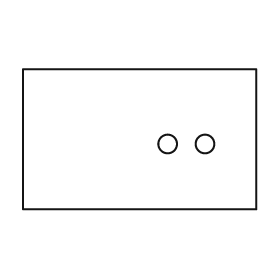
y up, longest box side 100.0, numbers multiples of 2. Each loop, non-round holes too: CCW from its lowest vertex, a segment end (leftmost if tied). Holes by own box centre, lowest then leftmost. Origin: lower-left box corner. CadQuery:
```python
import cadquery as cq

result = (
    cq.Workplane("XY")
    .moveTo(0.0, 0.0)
    .lineTo(100.0, 0.0)
    .lineTo(100.0, 60.0)
    .lineTo(0.0, 60.0)
    .close()
    .moveTo(62.0, 28.0)
    .circle(4.0)
    .moveTo(78.0, 28.0)
    .circle(4.0)
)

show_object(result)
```